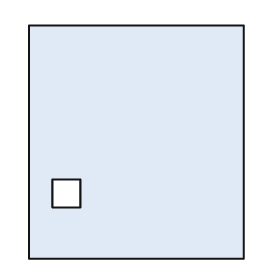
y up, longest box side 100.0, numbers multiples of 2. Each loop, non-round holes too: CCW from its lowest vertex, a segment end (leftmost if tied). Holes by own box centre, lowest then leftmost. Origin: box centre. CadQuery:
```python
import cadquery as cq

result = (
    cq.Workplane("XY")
    .moveTo(-46.0, -50.0)
    .lineTo(46.0, -50.0)
    .lineTo(46.0, 50.0)
    .lineTo(-46.0, 50.0)
    .close()
    .moveTo(-36.0, -28.0)
    .lineTo(-24.0, -28.0)
    .lineTo(-24.0, -16.0)
    .lineTo(-36.0, -16.0)
    .close()
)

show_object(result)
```